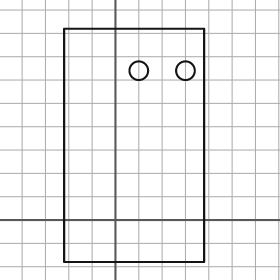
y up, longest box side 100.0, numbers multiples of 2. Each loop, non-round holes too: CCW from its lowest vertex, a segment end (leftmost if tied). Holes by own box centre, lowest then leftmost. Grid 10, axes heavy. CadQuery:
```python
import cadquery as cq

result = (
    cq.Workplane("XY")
    .moveTo(-22.0, -18.0)
    .lineTo(38.0, -18.0)
    .lineTo(38.0, 82.0)
    .lineTo(-22.0, 82.0)
    .close()
    .moveTo(10.0, 64.0)
    .circle(4.0)
    .moveTo(30.0, 64.0)
    .circle(4.0)
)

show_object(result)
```